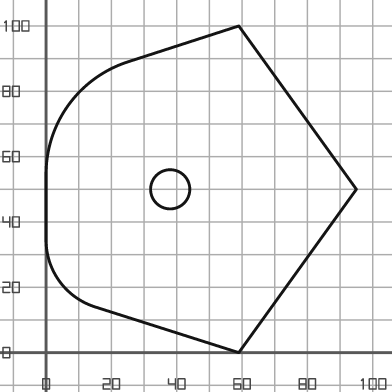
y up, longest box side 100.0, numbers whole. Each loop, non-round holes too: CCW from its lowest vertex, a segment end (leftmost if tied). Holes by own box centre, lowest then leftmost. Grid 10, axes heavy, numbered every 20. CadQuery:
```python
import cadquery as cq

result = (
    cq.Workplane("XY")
    .moveTo(59.0, 0.0)
    .lineTo(95.0, 50.0)
    .lineTo(59.0, 100.0)
    .lineTo(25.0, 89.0)
    .threePointArc((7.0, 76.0), (0.0, 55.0))
    .lineTo(0.0, 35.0)
    .threePointArc((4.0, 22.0), (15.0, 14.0))
    .close()
    .moveTo(38.0, 50.0)
    .circle(6.0)
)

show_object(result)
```